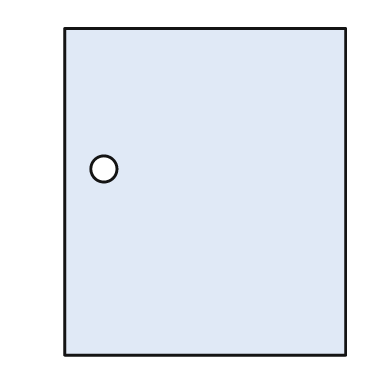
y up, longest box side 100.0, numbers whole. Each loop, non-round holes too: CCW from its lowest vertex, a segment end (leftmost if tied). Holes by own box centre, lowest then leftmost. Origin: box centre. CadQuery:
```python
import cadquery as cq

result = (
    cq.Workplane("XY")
    .moveTo(-43.0, -50.0)
    .lineTo(43.0, -50.0)
    .lineTo(43.0, 50.0)
    .lineTo(-43.0, 50.0)
    .close()
    .moveTo(-31.0, 7.0)
    .circle(4.0)
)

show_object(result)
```